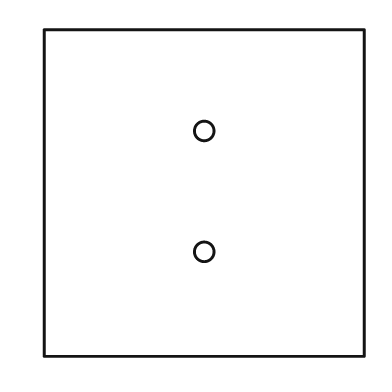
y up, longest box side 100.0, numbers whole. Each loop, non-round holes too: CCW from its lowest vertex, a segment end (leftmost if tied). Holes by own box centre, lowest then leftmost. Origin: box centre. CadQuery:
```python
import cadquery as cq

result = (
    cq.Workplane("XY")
    .moveTo(-49.0, -50.0)
    .lineTo(49.0, -50.0)
    .lineTo(49.0, 50.0)
    .lineTo(-49.0, 50.0)
    .close()
    .moveTo(0.0, -18.0)
    .circle(3.0)
    .moveTo(0.0, 19.0)
    .circle(3.0)
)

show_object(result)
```